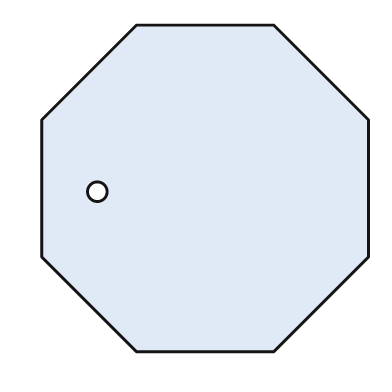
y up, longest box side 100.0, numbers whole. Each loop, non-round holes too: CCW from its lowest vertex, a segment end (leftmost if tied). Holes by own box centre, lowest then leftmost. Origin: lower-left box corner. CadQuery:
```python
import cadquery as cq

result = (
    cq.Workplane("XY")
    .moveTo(29.0, 0.0)
    .lineTo(71.0, 0.0)
    .lineTo(100.0, 29.0)
    .lineTo(100.0, 71.0)
    .lineTo(71.0, 100.0)
    .lineTo(29.0, 100.0)
    .lineTo(0.0, 71.0)
    .lineTo(0.0, 29.0)
    .close()
    .moveTo(17.0, 49.0)
    .circle(3.0)
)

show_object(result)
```